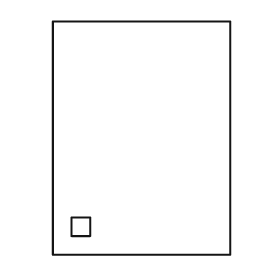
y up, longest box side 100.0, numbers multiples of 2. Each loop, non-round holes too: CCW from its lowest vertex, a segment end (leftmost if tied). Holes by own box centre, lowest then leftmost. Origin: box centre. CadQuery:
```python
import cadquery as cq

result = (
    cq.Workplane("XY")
    .moveTo(-38.0, -50.0)
    .lineTo(38.0, -50.0)
    .lineTo(38.0, 50.0)
    .lineTo(-38.0, 50.0)
    .close()
    .moveTo(-30.0, -42.0)
    .lineTo(-22.0, -42.0)
    .lineTo(-22.0, -34.0)
    .lineTo(-30.0, -34.0)
    .close()
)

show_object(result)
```